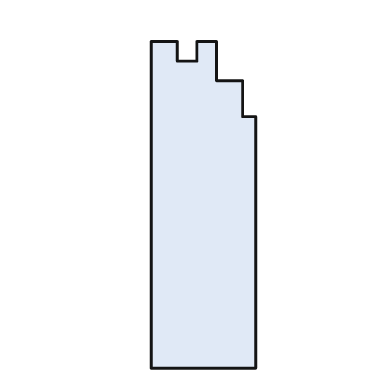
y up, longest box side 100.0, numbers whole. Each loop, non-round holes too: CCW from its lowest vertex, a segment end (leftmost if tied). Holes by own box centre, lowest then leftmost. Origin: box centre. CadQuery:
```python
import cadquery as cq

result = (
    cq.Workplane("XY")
    .moveTo(-16.0, -50.0)
    .lineTo(16.0, -50.0)
    .lineTo(16.0, 27.0)
    .lineTo(12.0, 27.0)
    .lineTo(12.0, 38.0)
    .lineTo(4.0, 38.0)
    .lineTo(4.0, 50.0)
    .lineTo(-2.0, 50.0)
    .lineTo(-2.0, 44.0)
    .lineTo(-8.0, 44.0)
    .lineTo(-8.0, 50.0)
    .lineTo(-16.0, 50.0)
    .close()
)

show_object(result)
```